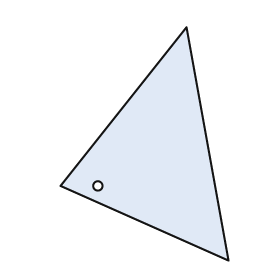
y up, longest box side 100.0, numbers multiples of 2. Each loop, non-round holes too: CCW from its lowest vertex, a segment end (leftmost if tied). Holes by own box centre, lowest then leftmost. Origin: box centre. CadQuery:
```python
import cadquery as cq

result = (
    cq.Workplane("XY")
    .moveTo(36.0, -50.0)
    .lineTo(18.0, 50.0)
    .lineTo(-36.0, -18.0)
    .close()
    .moveTo(-20.0, -18.0)
    .circle(2.0)
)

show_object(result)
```